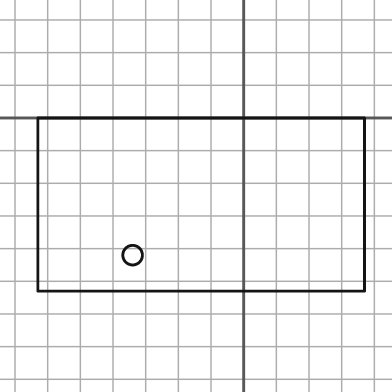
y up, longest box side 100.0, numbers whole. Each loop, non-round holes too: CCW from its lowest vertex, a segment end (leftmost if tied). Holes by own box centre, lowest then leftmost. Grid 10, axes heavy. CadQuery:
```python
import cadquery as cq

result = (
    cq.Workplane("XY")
    .moveTo(-63.0, -53.0)
    .lineTo(37.0, -53.0)
    .lineTo(37.0, 0.0)
    .lineTo(-63.0, 0.0)
    .close()
    .moveTo(-34.0, -42.0)
    .circle(3.0)
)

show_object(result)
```